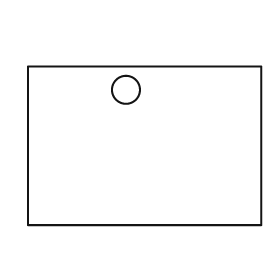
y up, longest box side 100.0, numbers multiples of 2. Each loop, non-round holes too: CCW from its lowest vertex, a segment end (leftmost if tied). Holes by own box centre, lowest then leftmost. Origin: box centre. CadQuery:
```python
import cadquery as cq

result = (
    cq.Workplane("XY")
    .moveTo(-50.0, -34.0)
    .lineTo(50.0, -34.0)
    .lineTo(50.0, 34.0)
    .lineTo(-50.0, 34.0)
    .close()
    .moveTo(-8.0, 24.0)
    .circle(6.0)
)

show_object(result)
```